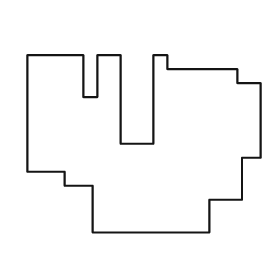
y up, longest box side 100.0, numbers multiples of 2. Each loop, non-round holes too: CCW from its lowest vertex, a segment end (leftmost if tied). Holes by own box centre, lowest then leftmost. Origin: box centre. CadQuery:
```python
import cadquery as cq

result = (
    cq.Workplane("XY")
    .moveTo(-22.0, -38.0)
    .lineTo(28.0, -38.0)
    .lineTo(28.0, -24.0)
    .lineTo(42.0, -24.0)
    .lineTo(42.0, -6.0)
    .lineTo(50.0, -6.0)
    .lineTo(50.0, 26.0)
    .lineTo(40.0, 26.0)
    .lineTo(40.0, 32.0)
    .lineTo(10.0, 32.0)
    .lineTo(10.0, 38.0)
    .lineTo(4.0, 38.0)
    .lineTo(4.0, 0.0)
    .lineTo(-10.0, 0.0)
    .lineTo(-10.0, 38.0)
    .lineTo(-20.0, 38.0)
    .lineTo(-20.0, 20.0)
    .lineTo(-26.0, 20.0)
    .lineTo(-26.0, 38.0)
    .lineTo(-50.0, 38.0)
    .lineTo(-50.0, -12.0)
    .lineTo(-34.0, -12.0)
    .lineTo(-34.0, -18.0)
    .lineTo(-22.0, -18.0)
    .close()
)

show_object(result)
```